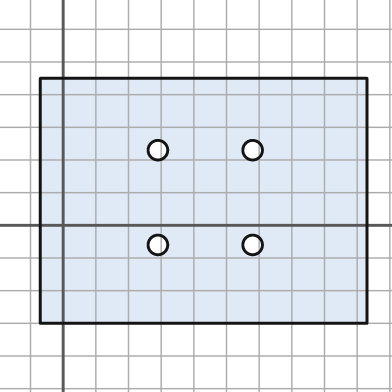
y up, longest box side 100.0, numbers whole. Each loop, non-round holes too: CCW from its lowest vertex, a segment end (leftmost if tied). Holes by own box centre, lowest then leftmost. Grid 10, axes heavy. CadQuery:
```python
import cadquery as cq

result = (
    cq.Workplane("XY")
    .moveTo(-7.0, -30.0)
    .lineTo(93.0, -30.0)
    .lineTo(93.0, 45.0)
    .lineTo(-7.0, 45.0)
    .close()
    .moveTo(29.0, -6.0)
    .circle(3.0)
    .moveTo(58.0, -6.0)
    .circle(3.0)
    .moveTo(29.0, 23.0)
    .circle(3.0)
    .moveTo(58.0, 23.0)
    .circle(3.0)
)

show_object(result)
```